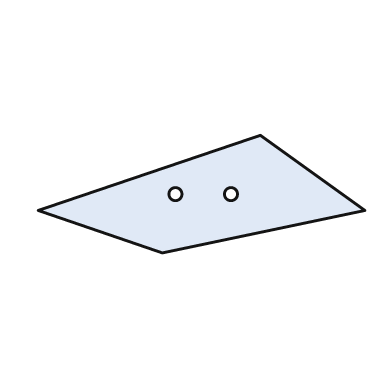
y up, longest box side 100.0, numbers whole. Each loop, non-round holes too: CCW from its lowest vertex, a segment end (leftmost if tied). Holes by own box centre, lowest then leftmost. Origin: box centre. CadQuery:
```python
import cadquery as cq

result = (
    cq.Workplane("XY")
    .moveTo(-12.0, -18.0)
    .lineTo(50.0, -5.0)
    .lineTo(18.0, 18.0)
    .lineTo(-50.0, -5.0)
    .close()
    .moveTo(-8.0, 0.0)
    .circle(2.0)
    .moveTo(9.0, 0.0)
    .circle(2.0)
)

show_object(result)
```